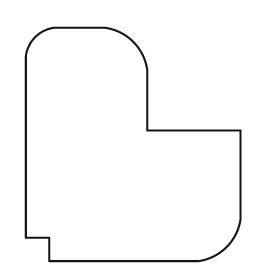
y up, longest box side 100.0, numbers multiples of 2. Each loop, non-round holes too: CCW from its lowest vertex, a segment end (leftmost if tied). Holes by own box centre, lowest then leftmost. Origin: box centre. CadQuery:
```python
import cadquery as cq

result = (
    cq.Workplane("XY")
    .moveTo(-36.0, -50.0)
    .lineTo(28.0, -50.0)
    .threePointArc((40.0, -44.0), (46.0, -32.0))
    .lineTo(46.0, 6.0)
    .lineTo(6.0, 6.0)
    .lineTo(6.0, 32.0)
    .threePointArc((0.0, 44.0), (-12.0, 50.0))
    .lineTo(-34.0, 50.0)
    .threePointArc((-42.0, 46.0), (-46.0, 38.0))
    .lineTo(-46.0, -40.0)
    .lineTo(-36.0, -40.0)
    .close()
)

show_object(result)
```